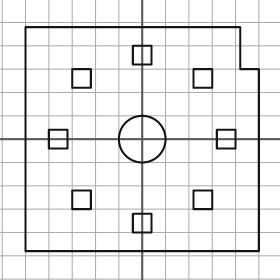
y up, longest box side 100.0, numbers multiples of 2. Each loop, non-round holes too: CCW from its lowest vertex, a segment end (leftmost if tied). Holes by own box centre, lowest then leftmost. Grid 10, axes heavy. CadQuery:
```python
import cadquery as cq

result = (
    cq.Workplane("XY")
    .moveTo(-50.0, -48.0)
    .lineTo(50.0, -48.0)
    .lineTo(50.0, 30.0)
    .lineTo(42.0, 30.0)
    .lineTo(42.0, 48.0)
    .lineTo(-50.0, 48.0)
    .close()
    .moveTo(-4.0, -40.0)
    .lineTo(4.0, -40.0)
    .lineTo(4.0, -32.0)
    .lineTo(-4.0, -32.0)
    .close()
    .moveTo(-30.0, -30.0)
    .lineTo(-22.0, -30.0)
    .lineTo(-22.0, -22.0)
    .lineTo(-30.0, -22.0)
    .close()
    .moveTo(22.0, -30.0)
    .lineTo(30.0, -30.0)
    .lineTo(30.0, -22.0)
    .lineTo(22.0, -22.0)
    .close()
    .moveTo(-40.0, -4.0)
    .lineTo(-32.0, -4.0)
    .lineTo(-32.0, 4.0)
    .lineTo(-40.0, 4.0)
    .close()
    .moveTo(0.0, 0.0)
    .circle(10.0)
    .moveTo(32.0, -4.0)
    .lineTo(40.0, -4.0)
    .lineTo(40.0, 4.0)
    .lineTo(32.0, 4.0)
    .close()
    .moveTo(-30.0, 22.0)
    .lineTo(-22.0, 22.0)
    .lineTo(-22.0, 30.0)
    .lineTo(-30.0, 30.0)
    .close()
    .moveTo(22.0, 22.0)
    .lineTo(30.0, 22.0)
    .lineTo(30.0, 30.0)
    .lineTo(22.0, 30.0)
    .close()
    .moveTo(-4.0, 32.0)
    .lineTo(4.0, 32.0)
    .lineTo(4.0, 40.0)
    .lineTo(-4.0, 40.0)
    .close()
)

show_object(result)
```